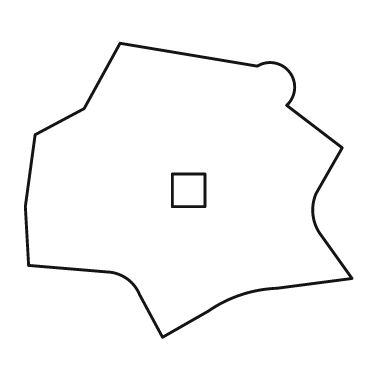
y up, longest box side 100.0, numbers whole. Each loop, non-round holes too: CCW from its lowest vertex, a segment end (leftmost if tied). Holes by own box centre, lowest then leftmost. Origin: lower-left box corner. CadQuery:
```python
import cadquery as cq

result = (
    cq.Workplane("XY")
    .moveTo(42.0, 0.0)
    .lineTo(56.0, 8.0)
    .threePointArc((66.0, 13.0), (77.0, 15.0))
    .lineTo(100.0, 18.0)
    .lineTo(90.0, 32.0)
    .threePointArc((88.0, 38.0), (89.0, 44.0))
    .lineTo(97.0, 58.0)
    .lineTo(80.0, 71.0)
    .threePointArc((81.0, 81.0), (71.0, 83.0))
    .lineTo(29.0, 90.0)
    .lineTo(18.0, 70.0)
    .lineTo(3.0, 62.0)
    .lineTo(0.0, 40.0)
    .lineTo(1.0, 22.0)
    .lineTo(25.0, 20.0)
    .threePointArc((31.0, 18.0), (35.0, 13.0))
    .close()
    .moveTo(45.0, 40.0)
    .lineTo(55.0, 40.0)
    .lineTo(55.0, 50.0)
    .lineTo(45.0, 50.0)
    .close()
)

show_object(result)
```